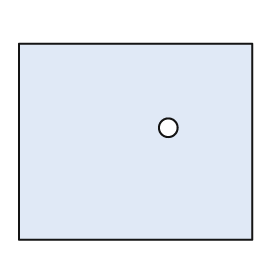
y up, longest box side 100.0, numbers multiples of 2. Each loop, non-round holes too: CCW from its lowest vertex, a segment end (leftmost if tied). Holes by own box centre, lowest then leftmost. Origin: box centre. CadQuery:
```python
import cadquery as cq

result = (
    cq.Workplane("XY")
    .moveTo(-50.0, -42.0)
    .lineTo(50.0, -42.0)
    .lineTo(50.0, 42.0)
    .lineTo(-50.0, 42.0)
    .close()
    .moveTo(14.0, 6.0)
    .circle(4.0)
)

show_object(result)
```